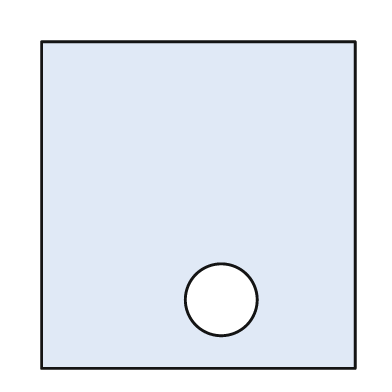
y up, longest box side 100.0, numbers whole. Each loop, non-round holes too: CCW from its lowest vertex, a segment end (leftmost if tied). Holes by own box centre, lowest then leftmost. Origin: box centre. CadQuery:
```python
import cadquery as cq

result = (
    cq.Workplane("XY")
    .moveTo(-48.0, -50.0)
    .lineTo(48.0, -50.0)
    .lineTo(48.0, 50.0)
    .lineTo(-48.0, 50.0)
    .close()
    .moveTo(7.0, -29.0)
    .circle(11.0)
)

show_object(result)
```